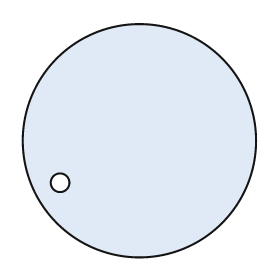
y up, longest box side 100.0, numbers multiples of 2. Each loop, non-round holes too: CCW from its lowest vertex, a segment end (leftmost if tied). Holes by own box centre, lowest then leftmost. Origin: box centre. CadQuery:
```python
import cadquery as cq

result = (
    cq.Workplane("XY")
    .moveTo(0.0, 0.0)
    .circle(50.0)
    .moveTo(-34.0, -18.0)
    .circle(4.0)
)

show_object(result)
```